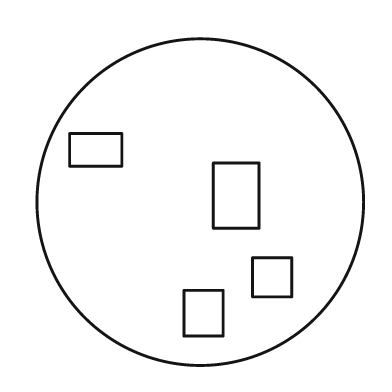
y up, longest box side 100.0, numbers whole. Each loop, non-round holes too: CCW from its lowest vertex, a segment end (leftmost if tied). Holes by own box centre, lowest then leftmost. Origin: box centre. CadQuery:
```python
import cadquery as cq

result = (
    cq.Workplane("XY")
    .moveTo(0.0, 0.0)
    .circle(50.0)
    .moveTo(-5.0, -41.0)
    .lineTo(7.0, -41.0)
    .lineTo(7.0, -27.0)
    .lineTo(-5.0, -27.0)
    .close()
    .moveTo(16.0, -29.0)
    .lineTo(28.0, -29.0)
    .lineTo(28.0, -17.0)
    .lineTo(16.0, -17.0)
    .close()
    .moveTo(4.0, -8.0)
    .lineTo(18.0, -8.0)
    .lineTo(18.0, 12.0)
    .lineTo(4.0, 12.0)
    .close()
    .moveTo(-40.0, 11.0)
    .lineTo(-24.0, 11.0)
    .lineTo(-24.0, 21.0)
    .lineTo(-40.0, 21.0)
    .close()
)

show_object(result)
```